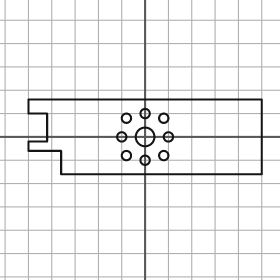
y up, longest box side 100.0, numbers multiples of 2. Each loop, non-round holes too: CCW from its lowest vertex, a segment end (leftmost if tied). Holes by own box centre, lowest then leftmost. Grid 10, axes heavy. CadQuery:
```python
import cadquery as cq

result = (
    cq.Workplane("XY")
    .moveTo(-36.0, -16.0)
    .lineTo(50.0, -16.0)
    .lineTo(50.0, 16.0)
    .lineTo(-50.0, 16.0)
    .lineTo(-50.0, 10.0)
    .lineTo(-42.0, 10.0)
    .lineTo(-42.0, -2.0)
    .lineTo(-50.0, -2.0)
    .lineTo(-50.0, -6.0)
    .lineTo(-36.0, -6.0)
    .close()
    .moveTo(0.0, -10.0)
    .circle(2.0)
    .moveTo(-8.0, -8.0)
    .circle(2.0)
    .moveTo(8.0, -8.0)
    .circle(2.0)
    .moveTo(-10.0, 0.0)
    .circle(2.0)
    .moveTo(0.0, 0.0)
    .circle(4.0)
    .moveTo(10.0, 0.0)
    .circle(2.0)
    .moveTo(-8.0, 8.0)
    .circle(2.0)
    .moveTo(8.0, 8.0)
    .circle(2.0)
    .moveTo(0.0, 10.0)
    .circle(2.0)
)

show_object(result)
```